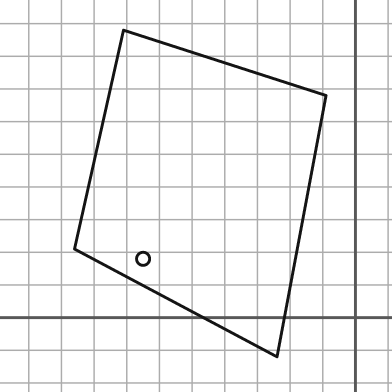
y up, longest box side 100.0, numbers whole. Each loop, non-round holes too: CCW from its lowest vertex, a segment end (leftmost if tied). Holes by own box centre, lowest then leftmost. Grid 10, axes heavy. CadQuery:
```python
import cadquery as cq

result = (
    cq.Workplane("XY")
    .moveTo(-24.0, -12.0)
    .lineTo(-9.0, 68.0)
    .lineTo(-71.0, 88.0)
    .lineTo(-86.0, 21.0)
    .close()
    .moveTo(-65.0, 18.0)
    .circle(2.0)
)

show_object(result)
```